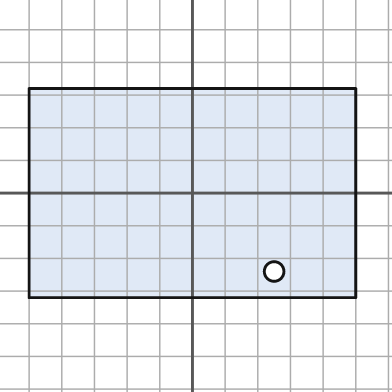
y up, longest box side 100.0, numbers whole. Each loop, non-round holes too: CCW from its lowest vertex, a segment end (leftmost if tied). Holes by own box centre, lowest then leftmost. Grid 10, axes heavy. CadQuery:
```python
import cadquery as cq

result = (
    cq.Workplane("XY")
    .moveTo(-50.0, -32.0)
    .lineTo(50.0, -32.0)
    .lineTo(50.0, 32.0)
    .lineTo(-50.0, 32.0)
    .close()
    .moveTo(25.0, -24.0)
    .circle(3.0)
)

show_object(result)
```